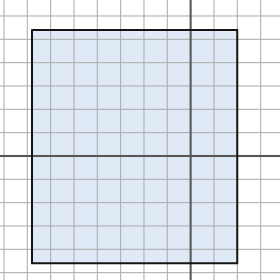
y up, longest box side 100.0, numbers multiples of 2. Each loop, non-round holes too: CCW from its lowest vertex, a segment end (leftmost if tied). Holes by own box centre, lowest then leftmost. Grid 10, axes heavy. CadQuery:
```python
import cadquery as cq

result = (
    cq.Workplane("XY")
    .moveTo(-68.0, -46.0)
    .lineTo(20.0, -46.0)
    .lineTo(20.0, 54.0)
    .lineTo(-68.0, 54.0)
    .close()
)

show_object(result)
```